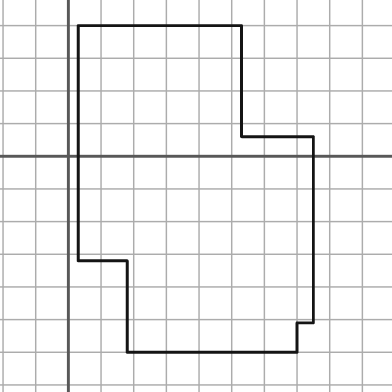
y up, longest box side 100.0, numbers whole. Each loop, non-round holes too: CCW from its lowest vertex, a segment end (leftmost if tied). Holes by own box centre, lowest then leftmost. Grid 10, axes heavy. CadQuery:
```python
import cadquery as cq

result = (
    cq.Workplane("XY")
    .moveTo(18.0, -60.0)
    .lineTo(70.0, -60.0)
    .lineTo(70.0, -51.0)
    .lineTo(75.0, -51.0)
    .lineTo(75.0, 6.0)
    .lineTo(53.0, 6.0)
    .lineTo(53.0, 40.0)
    .lineTo(3.0, 40.0)
    .lineTo(3.0, -32.0)
    .lineTo(18.0, -32.0)
    .close()
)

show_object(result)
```